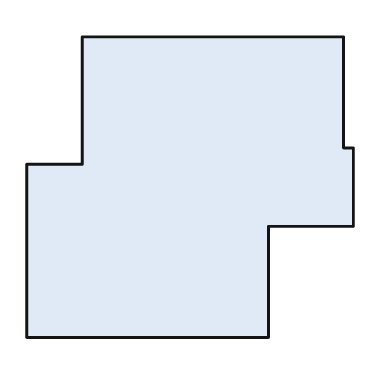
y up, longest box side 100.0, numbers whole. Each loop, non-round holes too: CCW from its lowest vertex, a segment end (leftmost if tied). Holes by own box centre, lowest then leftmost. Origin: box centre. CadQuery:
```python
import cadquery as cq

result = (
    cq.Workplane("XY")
    .moveTo(-50.0, -46.0)
    .lineTo(24.0, -46.0)
    .lineTo(24.0, -12.0)
    .lineTo(50.0, -12.0)
    .lineTo(50.0, 12.0)
    .lineTo(47.0, 12.0)
    .lineTo(47.0, 46.0)
    .lineTo(-33.0, 46.0)
    .lineTo(-33.0, 7.0)
    .lineTo(-50.0, 7.0)
    .close()
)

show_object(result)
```